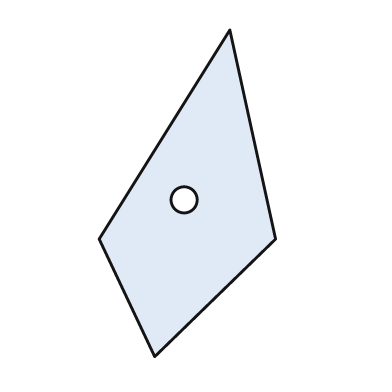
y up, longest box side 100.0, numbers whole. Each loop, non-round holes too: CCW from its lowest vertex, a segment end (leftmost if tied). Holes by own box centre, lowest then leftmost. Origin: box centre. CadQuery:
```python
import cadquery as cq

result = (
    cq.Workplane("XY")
    .moveTo(-10.0, -50.0)
    .lineTo(27.0, -14.0)
    .lineTo(13.0, 50.0)
    .lineTo(-27.0, -14.0)
    .close()
    .moveTo(-1.0, -2.0)
    .circle(4.0)
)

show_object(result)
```